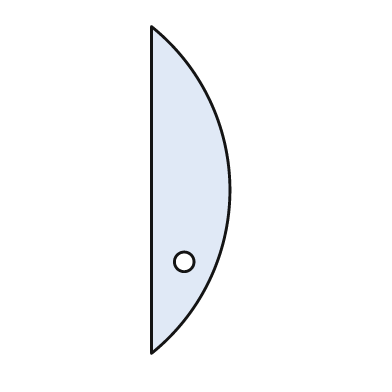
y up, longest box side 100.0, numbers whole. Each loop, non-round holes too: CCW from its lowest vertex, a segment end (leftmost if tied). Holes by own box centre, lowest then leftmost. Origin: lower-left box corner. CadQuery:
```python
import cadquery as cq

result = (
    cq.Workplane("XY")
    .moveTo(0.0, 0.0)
    .threePointArc((24.0, 50.0), (0.0, 100.0))
    .close()
    .moveTo(10.0, 28.0)
    .circle(3.0)
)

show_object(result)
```